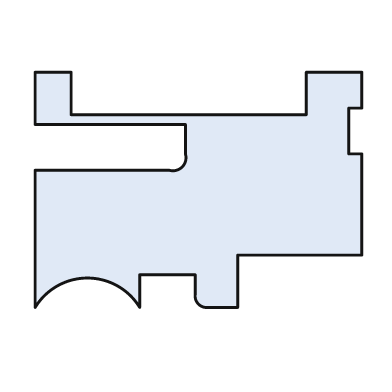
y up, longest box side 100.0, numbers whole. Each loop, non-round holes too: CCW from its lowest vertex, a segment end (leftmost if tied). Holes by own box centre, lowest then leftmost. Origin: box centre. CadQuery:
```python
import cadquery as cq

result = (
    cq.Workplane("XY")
    .moveTo(-50.0, -36.0)
    .threePointArc((-34.0, -27.0), (-18.0, -36.0))
    .lineTo(-18.0, -26.0)
    .lineTo(-1.0, -26.0)
    .lineTo(-1.0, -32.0)
    .threePointArc((0.0, -35.0), (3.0, -36.0))
    .lineTo(12.0, -36.0)
    .lineTo(12.0, -20.0)
    .lineTo(50.0, -20.0)
    .lineTo(50.0, 11.0)
    .lineTo(46.0, 11.0)
    .lineTo(46.0, 25.0)
    .lineTo(50.0, 25.0)
    .lineTo(50.0, 36.0)
    .lineTo(33.0, 36.0)
    .lineTo(33.0, 23.0)
    .lineTo(-39.0, 23.0)
    .lineTo(-39.0, 36.0)
    .lineTo(-50.0, 36.0)
    .lineTo(-50.0, 20.0)
    .lineTo(-4.0, 20.0)
    .lineTo(-4.0, 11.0)
    .threePointArc((-5.0, 7.0), (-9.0, 6.0))
    .lineTo(-50.0, 6.0)
    .close()
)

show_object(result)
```